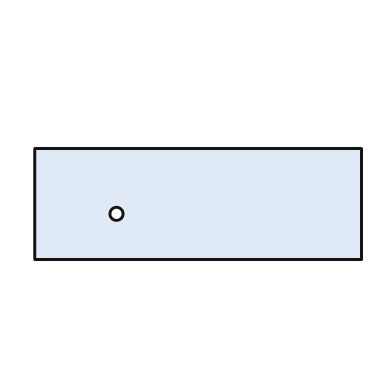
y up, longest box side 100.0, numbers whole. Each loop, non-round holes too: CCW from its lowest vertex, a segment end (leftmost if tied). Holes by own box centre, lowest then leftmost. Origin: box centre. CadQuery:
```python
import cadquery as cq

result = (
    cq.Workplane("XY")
    .moveTo(-50.0, -17.0)
    .lineTo(50.0, -17.0)
    .lineTo(50.0, 17.0)
    .lineTo(-50.0, 17.0)
    .close()
    .moveTo(-25.0, -3.0)
    .circle(2.0)
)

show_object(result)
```